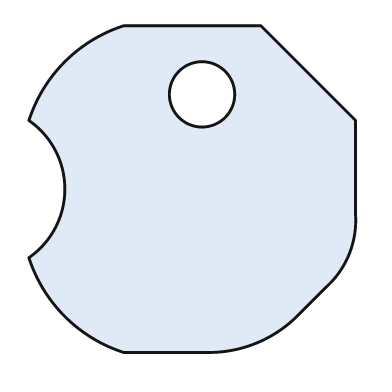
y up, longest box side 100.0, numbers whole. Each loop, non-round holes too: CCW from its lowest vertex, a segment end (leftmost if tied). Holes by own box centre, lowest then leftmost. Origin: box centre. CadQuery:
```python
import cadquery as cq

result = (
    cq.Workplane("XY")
    .moveTo(-21.0, -50.0)
    .lineTo(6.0, -50.0)
    .threePointArc((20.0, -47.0), (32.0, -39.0))
    .lineTo(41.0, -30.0)
    .threePointArc((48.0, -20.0), (50.0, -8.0))
    .lineTo(50.0, 21.0)
    .lineTo(21.0, 50.0)
    .lineTo(-21.0, 50.0)
    .threePointArc((-39.0, 39.0), (-50.0, 21.0))
    .threePointArc((-39.0, 0.0), (-50.0, -21.0))
    .threePointArc((-39.0, -39.0), (-21.0, -50.0))
    .close()
    .moveTo(3.0, 29.0)
    .circle(10.0)
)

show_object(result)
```